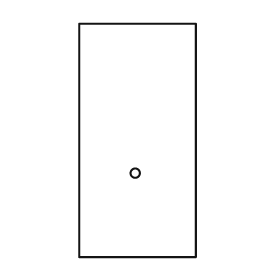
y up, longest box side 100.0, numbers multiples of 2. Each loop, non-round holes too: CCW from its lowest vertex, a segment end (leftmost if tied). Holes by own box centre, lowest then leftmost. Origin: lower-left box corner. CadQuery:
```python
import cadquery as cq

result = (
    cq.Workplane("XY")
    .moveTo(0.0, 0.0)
    .lineTo(50.0, 0.0)
    .lineTo(50.0, 100.0)
    .lineTo(0.0, 100.0)
    .close()
    .moveTo(24.0, 36.0)
    .circle(2.0)
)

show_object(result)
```